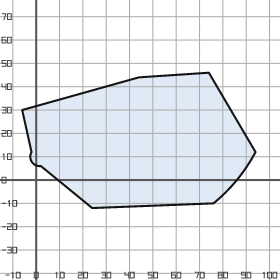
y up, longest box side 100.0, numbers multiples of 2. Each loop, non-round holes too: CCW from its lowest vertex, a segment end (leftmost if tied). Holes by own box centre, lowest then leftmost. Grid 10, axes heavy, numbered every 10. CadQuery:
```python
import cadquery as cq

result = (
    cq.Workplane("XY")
    .moveTo(24.0, -12.0)
    .lineTo(76.0, -10.0)
    .threePointArc((86.0, 0.0), (94.0, 12.0))
    .lineTo(74.0, 46.0)
    .lineTo(44.0, 44.0)
    .lineTo(-6.0, 30.0)
    .lineTo(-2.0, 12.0)
    .threePointArc((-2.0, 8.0), (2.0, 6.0))
    .close()
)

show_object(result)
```